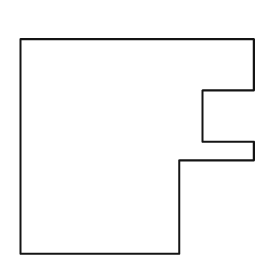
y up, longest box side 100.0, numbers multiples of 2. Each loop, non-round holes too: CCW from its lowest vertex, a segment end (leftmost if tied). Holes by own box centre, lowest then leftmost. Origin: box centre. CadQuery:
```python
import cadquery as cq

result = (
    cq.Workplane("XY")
    .moveTo(-50.0, -46.0)
    .lineTo(18.0, -46.0)
    .lineTo(18.0, -6.0)
    .lineTo(50.0, -6.0)
    .lineTo(50.0, 2.0)
    .lineTo(28.0, 2.0)
    .lineTo(28.0, 24.0)
    .lineTo(50.0, 24.0)
    .lineTo(50.0, 46.0)
    .lineTo(-50.0, 46.0)
    .close()
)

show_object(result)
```